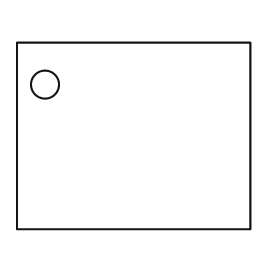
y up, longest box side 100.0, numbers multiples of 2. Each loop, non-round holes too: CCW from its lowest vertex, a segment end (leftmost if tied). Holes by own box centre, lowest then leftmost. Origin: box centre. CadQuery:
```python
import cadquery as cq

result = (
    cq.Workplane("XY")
    .moveTo(-50.0, -40.0)
    .lineTo(50.0, -40.0)
    .lineTo(50.0, 40.0)
    .lineTo(-50.0, 40.0)
    .close()
    .moveTo(-38.0, 22.0)
    .circle(6.0)
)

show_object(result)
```